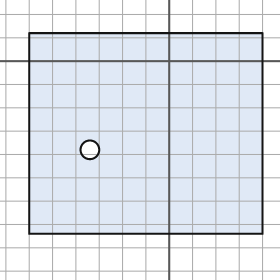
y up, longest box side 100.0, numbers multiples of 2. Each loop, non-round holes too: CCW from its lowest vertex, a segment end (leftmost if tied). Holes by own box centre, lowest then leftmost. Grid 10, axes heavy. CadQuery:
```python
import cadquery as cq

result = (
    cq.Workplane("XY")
    .moveTo(-60.0, -74.0)
    .lineTo(40.0, -74.0)
    .lineTo(40.0, 12.0)
    .lineTo(-60.0, 12.0)
    .close()
    .moveTo(-34.0, -38.0)
    .circle(4.0)
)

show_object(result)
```